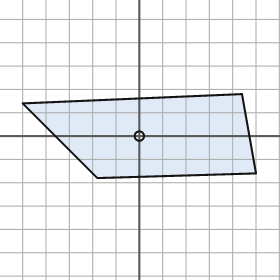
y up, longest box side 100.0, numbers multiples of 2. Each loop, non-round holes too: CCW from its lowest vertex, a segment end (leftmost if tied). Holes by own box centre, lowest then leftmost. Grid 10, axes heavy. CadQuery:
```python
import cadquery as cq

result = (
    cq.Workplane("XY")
    .moveTo(-18.0, -18.0)
    .lineTo(50.0, -16.0)
    .lineTo(44.0, 18.0)
    .lineTo(-50.0, 14.0)
    .close()
    .moveTo(0.0, 0.0)
    .circle(2.0)
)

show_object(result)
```